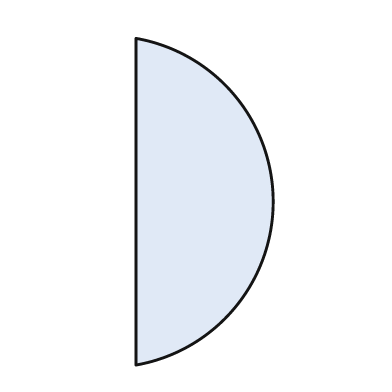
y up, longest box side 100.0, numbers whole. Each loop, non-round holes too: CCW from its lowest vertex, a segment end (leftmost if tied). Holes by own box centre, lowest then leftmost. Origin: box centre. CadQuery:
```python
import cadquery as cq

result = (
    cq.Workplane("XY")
    .moveTo(-21.0, -50.0)
    .threePointArc((21.0, 0.0), (-21.0, 50.0))
    .close()
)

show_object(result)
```